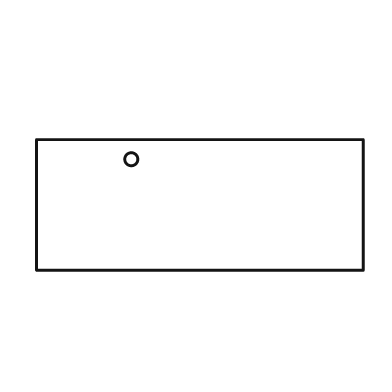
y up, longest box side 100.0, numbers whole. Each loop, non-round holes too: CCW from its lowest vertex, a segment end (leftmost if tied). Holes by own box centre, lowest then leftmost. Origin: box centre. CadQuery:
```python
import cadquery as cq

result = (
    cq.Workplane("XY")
    .moveTo(-50.0, -20.0)
    .lineTo(50.0, -20.0)
    .lineTo(50.0, 20.0)
    .lineTo(-50.0, 20.0)
    .close()
    .moveTo(-21.0, 14.0)
    .circle(2.0)
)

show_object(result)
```